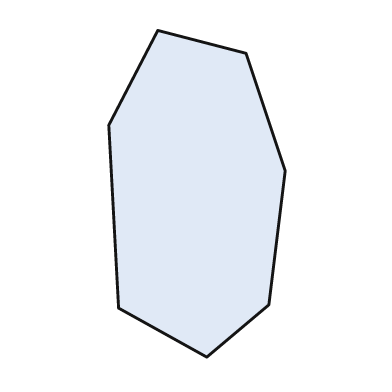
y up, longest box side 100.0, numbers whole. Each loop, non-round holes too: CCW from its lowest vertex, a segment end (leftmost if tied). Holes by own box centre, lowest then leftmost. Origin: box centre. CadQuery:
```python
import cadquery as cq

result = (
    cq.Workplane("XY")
    .moveTo(3.0, -50.0)
    .lineTo(22.0, -34.0)
    .lineTo(27.0, 7.0)
    .lineTo(15.0, 43.0)
    .lineTo(-12.0, 50.0)
    .lineTo(-27.0, 21.0)
    .lineTo(-24.0, -35.0)
    .close()
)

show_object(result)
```